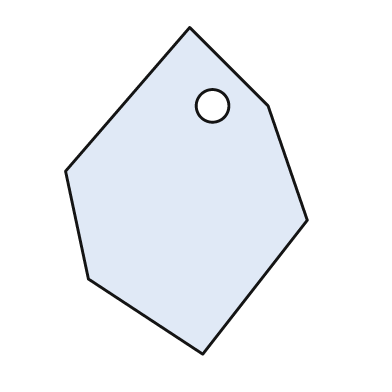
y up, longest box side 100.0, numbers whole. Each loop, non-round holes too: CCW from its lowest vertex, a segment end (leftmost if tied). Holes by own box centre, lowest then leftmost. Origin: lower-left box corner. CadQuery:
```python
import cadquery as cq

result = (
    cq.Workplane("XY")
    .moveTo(42.0, 0.0)
    .lineTo(74.0, 41.0)
    .lineTo(62.0, 76.0)
    .lineTo(38.0, 100.0)
    .lineTo(0.0, 56.0)
    .lineTo(7.0, 23.0)
    .close()
    .moveTo(45.0, 76.0)
    .circle(5.0)
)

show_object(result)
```